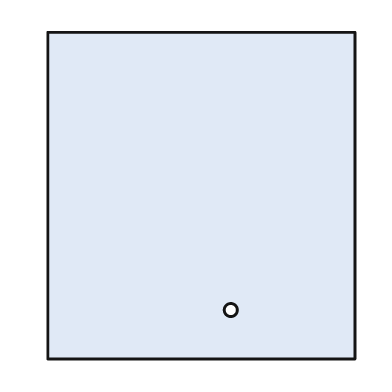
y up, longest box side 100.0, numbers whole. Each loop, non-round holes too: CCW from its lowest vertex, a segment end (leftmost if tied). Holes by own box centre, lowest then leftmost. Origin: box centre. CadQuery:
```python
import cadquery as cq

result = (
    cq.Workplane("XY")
    .moveTo(-47.0, -50.0)
    .lineTo(47.0, -50.0)
    .lineTo(47.0, 50.0)
    .lineTo(-47.0, 50.0)
    .close()
    .moveTo(9.0, -35.0)
    .circle(2.0)
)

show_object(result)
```